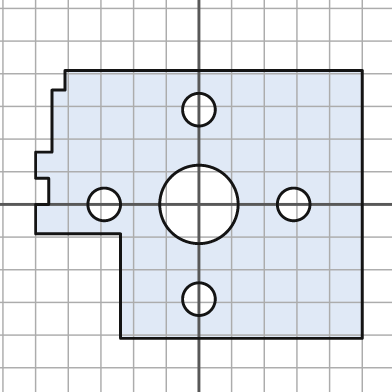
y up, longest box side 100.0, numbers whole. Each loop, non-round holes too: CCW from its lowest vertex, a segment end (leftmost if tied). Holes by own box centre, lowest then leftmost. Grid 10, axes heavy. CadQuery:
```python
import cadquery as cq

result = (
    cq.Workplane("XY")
    .moveTo(-24.0, -41.0)
    .lineTo(50.0, -41.0)
    .lineTo(50.0, 41.0)
    .lineTo(-41.0, 41.0)
    .lineTo(-41.0, 35.0)
    .lineTo(-45.0, 35.0)
    .lineTo(-45.0, 16.0)
    .lineTo(-50.0, 16.0)
    .lineTo(-50.0, 8.0)
    .lineTo(-46.0, 8.0)
    .lineTo(-46.0, 0.0)
    .lineTo(-50.0, 0.0)
    .lineTo(-50.0, -9.0)
    .lineTo(-24.0, -9.0)
    .close()
    .moveTo(0.0, -29.0)
    .circle(5.0)
    .moveTo(-29.0, 0.0)
    .circle(5.0)
    .moveTo(0.0, 0.0)
    .circle(12.0)
    .moveTo(29.0, 0.0)
    .circle(5.0)
    .moveTo(0.0, 29.0)
    .circle(5.0)
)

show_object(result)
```